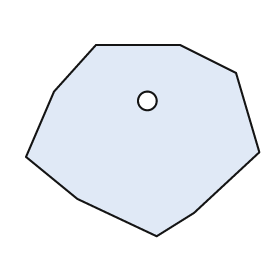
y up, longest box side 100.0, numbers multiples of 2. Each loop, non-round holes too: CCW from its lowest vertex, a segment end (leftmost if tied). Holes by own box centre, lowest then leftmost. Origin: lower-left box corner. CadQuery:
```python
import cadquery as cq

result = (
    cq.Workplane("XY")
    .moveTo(56.0, 0.0)
    .lineTo(72.0, 10.0)
    .lineTo(100.0, 36.0)
    .lineTo(90.0, 70.0)
    .lineTo(66.0, 82.0)
    .lineTo(30.0, 82.0)
    .lineTo(12.0, 62.0)
    .lineTo(0.0, 34.0)
    .lineTo(22.0, 16.0)
    .close()
    .moveTo(52.0, 58.0)
    .circle(4.0)
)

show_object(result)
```